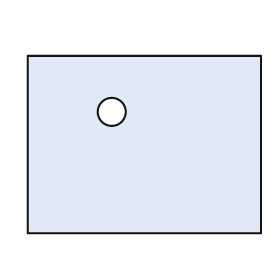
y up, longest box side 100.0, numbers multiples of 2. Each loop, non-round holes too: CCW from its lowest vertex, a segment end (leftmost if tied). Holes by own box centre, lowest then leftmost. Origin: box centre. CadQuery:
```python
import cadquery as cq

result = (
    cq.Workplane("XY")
    .moveTo(-50.0, -38.0)
    .lineTo(50.0, -38.0)
    .lineTo(50.0, 38.0)
    .lineTo(-50.0, 38.0)
    .close()
    .moveTo(-14.0, 14.0)
    .circle(6.0)
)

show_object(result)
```